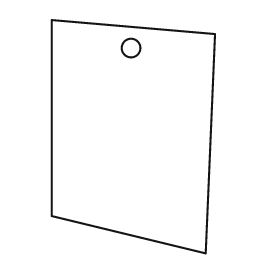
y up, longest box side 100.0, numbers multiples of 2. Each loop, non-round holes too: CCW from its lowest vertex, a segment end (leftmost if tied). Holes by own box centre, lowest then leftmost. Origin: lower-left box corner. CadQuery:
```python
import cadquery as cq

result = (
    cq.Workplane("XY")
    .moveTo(66.0, 0.0)
    .lineTo(70.0, 94.0)
    .lineTo(0.0, 100.0)
    .lineTo(0.0, 16.0)
    .close()
    .moveTo(34.0, 88.0)
    .circle(4.0)
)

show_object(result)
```